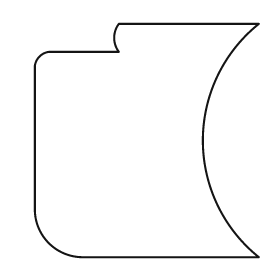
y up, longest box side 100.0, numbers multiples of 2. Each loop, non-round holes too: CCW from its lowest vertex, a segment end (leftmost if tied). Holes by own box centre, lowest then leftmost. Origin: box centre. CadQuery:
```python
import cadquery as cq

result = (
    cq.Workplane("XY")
    .moveTo(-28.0, -50.0)
    .lineTo(48.0, -50.0)
    .threePointArc((24.0, 0.0), (48.0, 50.0))
    .lineTo(-12.0, 50.0)
    .threePointArc((-14.0, 44.0), (-12.0, 38.0))
    .lineTo(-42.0, 38.0)
    .threePointArc((-46.0, 36.0), (-48.0, 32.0))
    .lineTo(-48.0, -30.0)
    .threePointArc((-42.0, -44.0), (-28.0, -50.0))
    .close()
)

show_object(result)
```